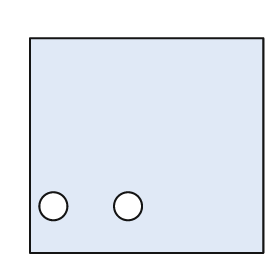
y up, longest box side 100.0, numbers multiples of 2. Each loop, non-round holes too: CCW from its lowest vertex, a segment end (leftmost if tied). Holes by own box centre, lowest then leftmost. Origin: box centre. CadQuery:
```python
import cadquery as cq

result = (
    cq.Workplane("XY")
    .moveTo(-50.0, -46.0)
    .lineTo(50.0, -46.0)
    .lineTo(50.0, 46.0)
    .lineTo(-50.0, 46.0)
    .close()
    .moveTo(-40.0, -26.0)
    .circle(6.0)
    .moveTo(-8.0, -26.0)
    .circle(6.0)
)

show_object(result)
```